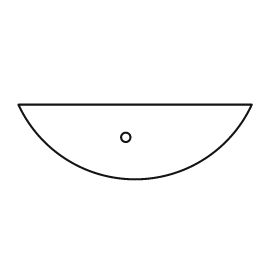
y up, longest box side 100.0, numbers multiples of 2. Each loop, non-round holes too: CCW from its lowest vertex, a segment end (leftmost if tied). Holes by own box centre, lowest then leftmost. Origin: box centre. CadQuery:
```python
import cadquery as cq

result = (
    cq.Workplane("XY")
    .moveTo(-50.0, 16.0)
    .threePointArc((0.0, -16.0), (50.0, 16.0))
    .close()
    .moveTo(-4.0, 2.0)
    .circle(2.0)
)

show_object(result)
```